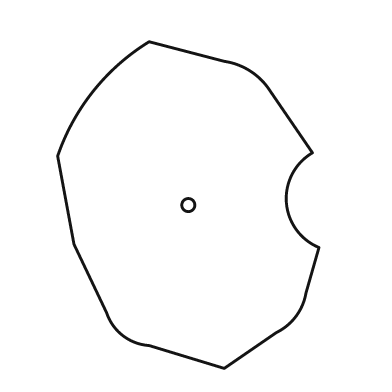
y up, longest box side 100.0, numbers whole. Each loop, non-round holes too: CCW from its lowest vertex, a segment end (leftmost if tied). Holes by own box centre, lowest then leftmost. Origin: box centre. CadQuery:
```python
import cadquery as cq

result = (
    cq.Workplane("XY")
    .moveTo(11.0, -50.0)
    .lineTo(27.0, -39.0)
    .threePointArc((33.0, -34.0), (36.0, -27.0))
    .lineTo(40.0, -13.0)
    .threePointArc((30.0, 1.0), (38.0, 16.0))
    .lineTo(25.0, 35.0)
    .threePointArc((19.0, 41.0), (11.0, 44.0))
    .lineTo(-12.0, 50.0)
    .threePointArc((-29.0, 35.0), (-40.0, 15.0))
    .lineTo(-35.0, -12.0)
    .lineTo(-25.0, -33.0)
    .threePointArc((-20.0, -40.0), (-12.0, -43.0))
    .close()
    .moveTo(0.0, 0.0)
    .circle(2.0)
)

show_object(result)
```